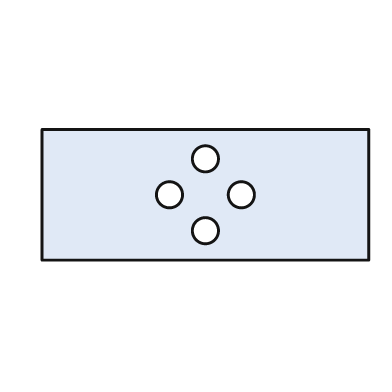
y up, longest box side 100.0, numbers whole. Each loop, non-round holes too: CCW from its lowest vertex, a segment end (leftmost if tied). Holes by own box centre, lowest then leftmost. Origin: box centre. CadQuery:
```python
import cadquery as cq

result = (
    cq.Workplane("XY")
    .moveTo(-50.0, -20.0)
    .lineTo(50.0, -20.0)
    .lineTo(50.0, 20.0)
    .lineTo(-50.0, 20.0)
    .close()
    .moveTo(0.0, -11.0)
    .circle(4.0)
    .moveTo(-11.0, 0.0)
    .circle(4.0)
    .moveTo(11.0, 0.0)
    .circle(4.0)
    .moveTo(0.0, 11.0)
    .circle(4.0)
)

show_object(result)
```